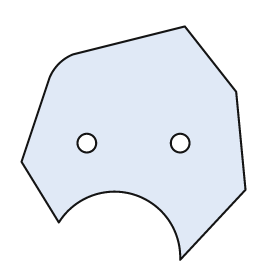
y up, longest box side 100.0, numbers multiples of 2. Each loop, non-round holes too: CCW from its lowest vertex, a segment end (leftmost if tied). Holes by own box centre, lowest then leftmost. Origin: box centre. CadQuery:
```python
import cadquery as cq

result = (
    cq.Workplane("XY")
    .moveTo(20.0, -50.0)
    .lineTo(48.0, -20.0)
    .lineTo(44.0, 22.0)
    .lineTo(22.0, 50.0)
    .lineTo(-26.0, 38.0)
    .threePointArc((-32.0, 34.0), (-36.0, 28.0))
    .lineTo(-48.0, -8.0)
    .lineTo(-32.0, -34.0)
    .threePointArc((0.0, -22.0), (20.0, -50.0))
    .close()
    .moveTo(-20.0, 0.0)
    .circle(4.0)
    .moveTo(20.0, 0.0)
    .circle(4.0)
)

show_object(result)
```